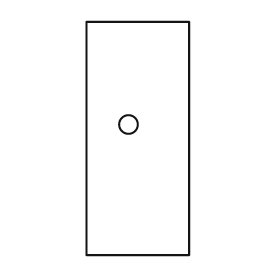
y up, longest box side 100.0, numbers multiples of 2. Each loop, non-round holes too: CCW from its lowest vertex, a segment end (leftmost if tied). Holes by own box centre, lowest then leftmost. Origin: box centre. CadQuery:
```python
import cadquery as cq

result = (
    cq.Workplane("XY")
    .moveTo(-22.0, -50.0)
    .lineTo(22.0, -50.0)
    .lineTo(22.0, 50.0)
    .lineTo(-22.0, 50.0)
    .close()
    .moveTo(-4.0, 6.0)
    .circle(4.0)
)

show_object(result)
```